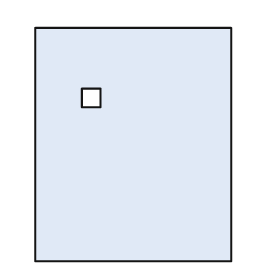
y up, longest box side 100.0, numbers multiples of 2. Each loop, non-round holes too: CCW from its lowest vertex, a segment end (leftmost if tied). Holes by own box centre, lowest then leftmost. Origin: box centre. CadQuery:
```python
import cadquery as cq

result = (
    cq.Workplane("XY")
    .moveTo(-42.0, -50.0)
    .lineTo(42.0, -50.0)
    .lineTo(42.0, 50.0)
    .lineTo(-42.0, 50.0)
    .close()
    .moveTo(-22.0, 16.0)
    .lineTo(-14.0, 16.0)
    .lineTo(-14.0, 24.0)
    .lineTo(-22.0, 24.0)
    .close()
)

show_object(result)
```